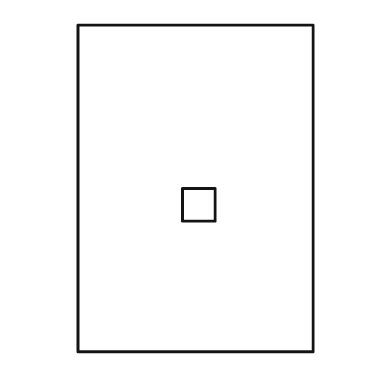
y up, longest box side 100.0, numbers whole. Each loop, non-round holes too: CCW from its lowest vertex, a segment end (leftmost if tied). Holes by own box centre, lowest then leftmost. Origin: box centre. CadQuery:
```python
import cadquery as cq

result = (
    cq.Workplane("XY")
    .moveTo(-36.0, -50.0)
    .lineTo(36.0, -50.0)
    .lineTo(36.0, 50.0)
    .lineTo(-36.0, 50.0)
    .close()
    .moveTo(-4.0, -10.0)
    .lineTo(6.0, -10.0)
    .lineTo(6.0, 0.0)
    .lineTo(-4.0, 0.0)
    .close()
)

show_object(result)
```